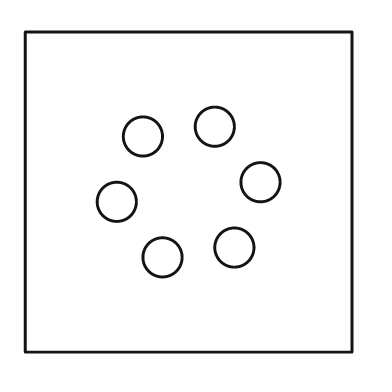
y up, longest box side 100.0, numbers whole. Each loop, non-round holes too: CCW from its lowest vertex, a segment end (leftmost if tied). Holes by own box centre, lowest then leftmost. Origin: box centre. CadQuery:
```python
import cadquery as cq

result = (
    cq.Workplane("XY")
    .moveTo(-50.0, -49.0)
    .lineTo(50.0, -49.0)
    .lineTo(50.0, 49.0)
    .lineTo(-50.0, 49.0)
    .close()
    .moveTo(-8.0, -20.0)
    .circle(6.0)
    .moveTo(14.0, -17.0)
    .circle(6.0)
    .moveTo(-22.0, -3.0)
    .circle(6.0)
    .moveTo(22.0, 3.0)
    .circle(6.0)
    .moveTo(-14.0, 17.0)
    .circle(6.0)
    .moveTo(8.0, 20.0)
    .circle(6.0)
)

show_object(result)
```